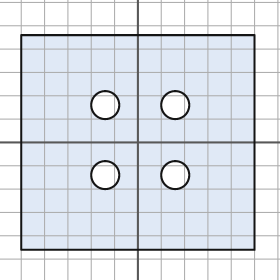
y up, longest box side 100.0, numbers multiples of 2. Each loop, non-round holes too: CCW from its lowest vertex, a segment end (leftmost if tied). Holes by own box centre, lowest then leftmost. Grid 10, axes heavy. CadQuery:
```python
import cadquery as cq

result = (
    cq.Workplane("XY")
    .moveTo(-50.0, -46.0)
    .lineTo(50.0, -46.0)
    .lineTo(50.0, 46.0)
    .lineTo(-50.0, 46.0)
    .close()
    .moveTo(-14.0, -14.0)
    .circle(6.0)
    .moveTo(16.0, -14.0)
    .circle(6.0)
    .moveTo(-14.0, 16.0)
    .circle(6.0)
    .moveTo(16.0, 16.0)
    .circle(6.0)
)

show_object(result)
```